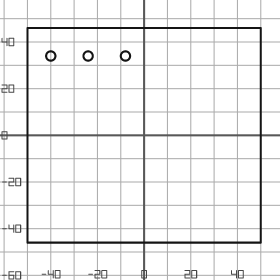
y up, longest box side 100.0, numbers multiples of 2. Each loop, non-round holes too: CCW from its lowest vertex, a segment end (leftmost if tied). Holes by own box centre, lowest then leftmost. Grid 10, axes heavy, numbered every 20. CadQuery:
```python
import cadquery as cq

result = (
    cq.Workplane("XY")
    .moveTo(-50.0, -46.0)
    .lineTo(50.0, -46.0)
    .lineTo(50.0, 46.0)
    .lineTo(-50.0, 46.0)
    .close()
    .moveTo(-40.0, 34.0)
    .circle(2.0)
    .moveTo(-24.0, 34.0)
    .circle(2.0)
    .moveTo(-8.0, 34.0)
    .circle(2.0)
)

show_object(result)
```